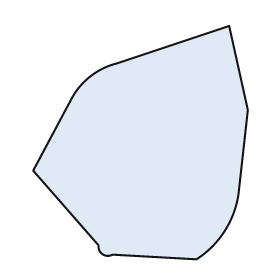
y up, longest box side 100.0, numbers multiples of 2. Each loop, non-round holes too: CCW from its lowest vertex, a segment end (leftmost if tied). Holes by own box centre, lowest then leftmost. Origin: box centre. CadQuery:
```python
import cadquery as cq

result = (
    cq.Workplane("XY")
    .moveTo(24.0, -50.0)
    .threePointArc((36.0, -38.0), (42.0, -22.0))
    .lineTo(46.0, 14.0)
    .lineTo(38.0, 50.0)
    .lineTo(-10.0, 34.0)
    .threePointArc((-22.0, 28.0), (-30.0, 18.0))
    .lineTo(-46.0, -12.0)
    .lineTo(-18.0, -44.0)
    .threePointArc((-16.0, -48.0), (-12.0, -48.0))
    .close()
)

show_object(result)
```